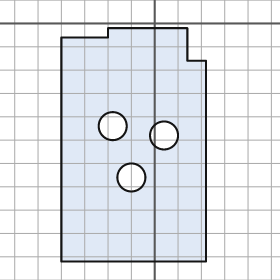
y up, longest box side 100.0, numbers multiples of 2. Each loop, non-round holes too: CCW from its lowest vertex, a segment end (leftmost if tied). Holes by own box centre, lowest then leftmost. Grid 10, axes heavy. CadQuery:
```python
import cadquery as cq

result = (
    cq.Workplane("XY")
    .moveTo(-40.0, -102.0)
    .lineTo(22.0, -102.0)
    .lineTo(22.0, -16.0)
    .lineTo(14.0, -16.0)
    .lineTo(14.0, -2.0)
    .lineTo(-20.0, -2.0)
    .lineTo(-20.0, -6.0)
    .lineTo(-40.0, -6.0)
    .close()
    .moveTo(-10.0, -66.0)
    .circle(6.0)
    .moveTo(4.0, -48.0)
    .circle(6.0)
    .moveTo(-18.0, -44.0)
    .circle(6.0)
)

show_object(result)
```